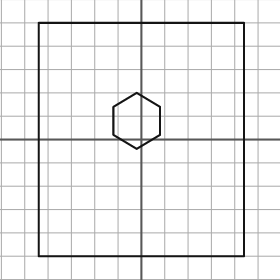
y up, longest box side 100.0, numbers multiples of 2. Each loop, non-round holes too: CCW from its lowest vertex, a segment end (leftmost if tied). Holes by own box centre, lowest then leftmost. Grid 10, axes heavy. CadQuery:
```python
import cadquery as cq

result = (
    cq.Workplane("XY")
    .moveTo(-44.0, -50.0)
    .lineTo(44.0, -50.0)
    .lineTo(44.0, 50.0)
    .lineTo(-44.0, 50.0)
    .close()
    .moveTo(-2.0, -4.0)
    .lineTo(8.0, 2.0)
    .lineTo(8.0, 14.0)
    .lineTo(-2.0, 20.0)
    .lineTo(-12.0, 14.0)
    .lineTo(-12.0, 2.0)
    .close()
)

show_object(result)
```